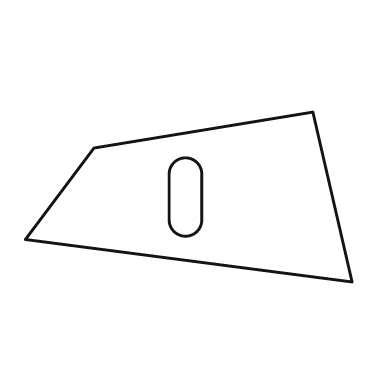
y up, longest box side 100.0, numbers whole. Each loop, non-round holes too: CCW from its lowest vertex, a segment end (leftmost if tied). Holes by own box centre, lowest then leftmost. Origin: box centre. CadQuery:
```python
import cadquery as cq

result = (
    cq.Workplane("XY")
    .moveTo(50.0, -26.0)
    .lineTo(38.0, 26.0)
    .lineTo(-29.0, 15.0)
    .lineTo(-50.0, -13.0)
    .close()
    .moveTo(-6.0, -7.0)
    .threePointArc((-1.0, -12.0), (4.0, -7.0))
    .lineTo(4.0, 7.0)
    .threePointArc((-1.0, 12.0), (-6.0, 7.0))
    .close()
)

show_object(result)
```